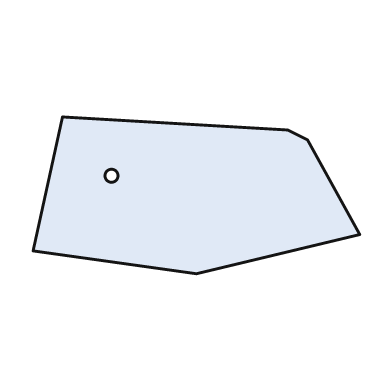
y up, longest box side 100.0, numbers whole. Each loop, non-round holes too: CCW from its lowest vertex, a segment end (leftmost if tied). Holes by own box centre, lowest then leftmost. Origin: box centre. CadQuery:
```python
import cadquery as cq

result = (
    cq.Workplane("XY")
    .moveTo(0.0, -24.0)
    .lineTo(50.0, -12.0)
    .lineTo(34.0, 17.0)
    .lineTo(28.0, 20.0)
    .lineTo(-41.0, 24.0)
    .lineTo(-50.0, -17.0)
    .close()
    .moveTo(-26.0, 6.0)
    .circle(2.0)
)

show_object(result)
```